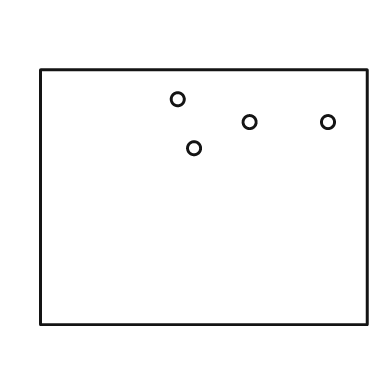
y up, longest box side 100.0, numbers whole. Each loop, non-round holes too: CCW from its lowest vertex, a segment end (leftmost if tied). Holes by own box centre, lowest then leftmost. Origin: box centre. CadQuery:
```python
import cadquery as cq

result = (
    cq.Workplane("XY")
    .moveTo(-50.0, -39.0)
    .lineTo(50.0, -39.0)
    .lineTo(50.0, 39.0)
    .lineTo(-50.0, 39.0)
    .close()
    .moveTo(-3.0, 15.0)
    .circle(2.0)
    .moveTo(14.0, 23.0)
    .circle(2.0)
    .moveTo(38.0, 23.0)
    .circle(2.0)
    .moveTo(-8.0, 30.0)
    .circle(2.0)
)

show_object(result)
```